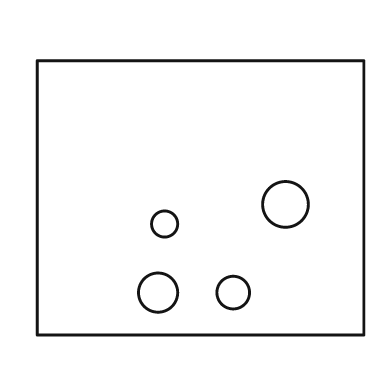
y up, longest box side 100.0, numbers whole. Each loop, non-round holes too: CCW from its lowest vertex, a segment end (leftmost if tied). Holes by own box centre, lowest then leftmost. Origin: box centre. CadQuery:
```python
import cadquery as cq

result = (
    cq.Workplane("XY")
    .moveTo(-50.0, -42.0)
    .lineTo(50.0, -42.0)
    .lineTo(50.0, 42.0)
    .lineTo(-50.0, 42.0)
    .close()
    .moveTo(-13.0, -29.0)
    .circle(6.0)
    .moveTo(10.0, -29.0)
    .circle(5.0)
    .moveTo(-11.0, -8.0)
    .circle(4.0)
    .moveTo(26.0, -2.0)
    .circle(7.0)
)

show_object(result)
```